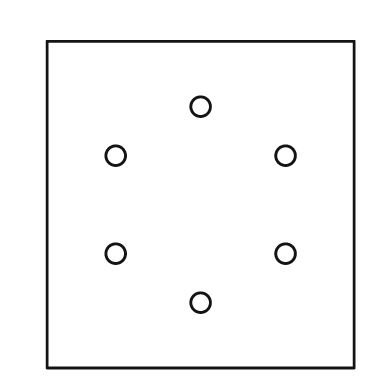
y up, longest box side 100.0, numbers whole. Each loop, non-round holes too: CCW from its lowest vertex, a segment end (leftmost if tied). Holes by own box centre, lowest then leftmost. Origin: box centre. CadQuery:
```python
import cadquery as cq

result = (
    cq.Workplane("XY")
    .moveTo(-47.0, -50.0)
    .lineTo(47.0, -50.0)
    .lineTo(47.0, 50.0)
    .lineTo(-47.0, 50.0)
    .close()
    .moveTo(0.0, -30.0)
    .circle(3.0)
    .moveTo(-26.0, -15.0)
    .circle(3.0)
    .moveTo(26.0, -15.0)
    .circle(3.0)
    .moveTo(-26.0, 15.0)
    .circle(3.0)
    .moveTo(26.0, 15.0)
    .circle(3.0)
    .moveTo(0.0, 30.0)
    .circle(3.0)
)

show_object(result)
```